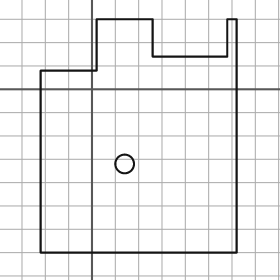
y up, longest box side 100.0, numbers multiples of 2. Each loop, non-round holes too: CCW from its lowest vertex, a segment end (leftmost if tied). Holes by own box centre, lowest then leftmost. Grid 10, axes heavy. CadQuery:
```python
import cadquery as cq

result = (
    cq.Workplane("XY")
    .moveTo(-22.0, -70.0)
    .lineTo(62.0, -70.0)
    .lineTo(62.0, 30.0)
    .lineTo(58.0, 30.0)
    .lineTo(58.0, 14.0)
    .lineTo(26.0, 14.0)
    .lineTo(26.0, 30.0)
    .lineTo(2.0, 30.0)
    .lineTo(2.0, 8.0)
    .lineTo(-22.0, 8.0)
    .close()
    .moveTo(14.0, -32.0)
    .circle(4.0)
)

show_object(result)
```